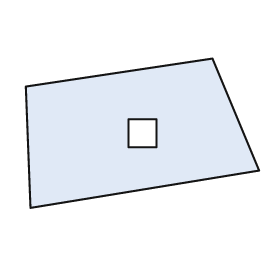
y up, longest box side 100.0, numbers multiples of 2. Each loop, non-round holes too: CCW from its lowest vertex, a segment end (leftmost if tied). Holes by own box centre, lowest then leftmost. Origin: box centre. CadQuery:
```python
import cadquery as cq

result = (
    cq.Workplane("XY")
    .moveTo(-48.0, -32.0)
    .lineTo(50.0, -16.0)
    .lineTo(30.0, 32.0)
    .lineTo(-50.0, 20.0)
    .close()
    .moveTo(-6.0, -6.0)
    .lineTo(6.0, -6.0)
    .lineTo(6.0, 6.0)
    .lineTo(-6.0, 6.0)
    .close()
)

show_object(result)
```